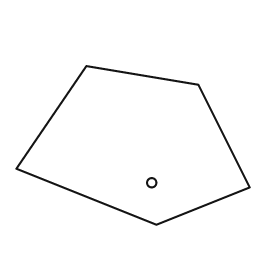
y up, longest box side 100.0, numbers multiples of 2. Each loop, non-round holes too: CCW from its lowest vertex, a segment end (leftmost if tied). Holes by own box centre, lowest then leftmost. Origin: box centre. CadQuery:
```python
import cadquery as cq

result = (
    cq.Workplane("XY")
    .moveTo(10.0, -34.0)
    .lineTo(50.0, -18.0)
    .lineTo(28.0, 26.0)
    .lineTo(-20.0, 34.0)
    .lineTo(-50.0, -10.0)
    .close()
    .moveTo(8.0, -16.0)
    .circle(2.0)
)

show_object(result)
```